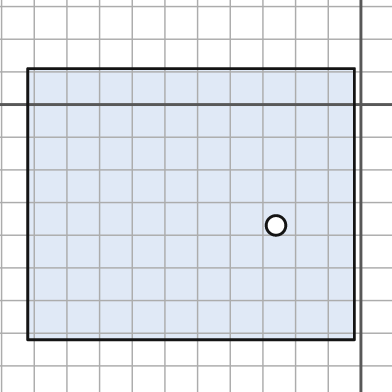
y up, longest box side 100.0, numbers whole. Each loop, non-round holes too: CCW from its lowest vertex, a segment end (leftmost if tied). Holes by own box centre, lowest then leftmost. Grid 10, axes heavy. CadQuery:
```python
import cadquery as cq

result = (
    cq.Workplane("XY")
    .moveTo(-102.0, -72.0)
    .lineTo(-2.0, -72.0)
    .lineTo(-2.0, 11.0)
    .lineTo(-102.0, 11.0)
    .close()
    .moveTo(-26.0, -37.0)
    .circle(3.0)
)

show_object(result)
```